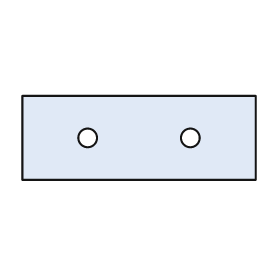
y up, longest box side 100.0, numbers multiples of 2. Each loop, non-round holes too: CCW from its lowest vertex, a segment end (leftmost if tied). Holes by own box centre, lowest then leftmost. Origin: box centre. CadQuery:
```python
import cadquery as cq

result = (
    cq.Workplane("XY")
    .moveTo(-50.0, -18.0)
    .lineTo(50.0, -18.0)
    .lineTo(50.0, 18.0)
    .lineTo(-50.0, 18.0)
    .close()
    .moveTo(-22.0, 0.0)
    .circle(4.0)
    .moveTo(22.0, 0.0)
    .circle(4.0)
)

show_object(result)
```